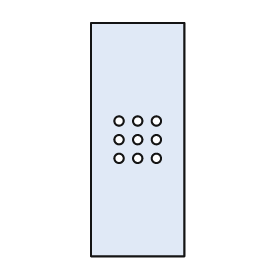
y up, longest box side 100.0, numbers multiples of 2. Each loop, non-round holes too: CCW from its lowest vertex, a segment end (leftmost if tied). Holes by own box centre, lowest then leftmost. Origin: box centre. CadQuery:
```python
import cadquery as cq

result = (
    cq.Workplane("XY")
    .moveTo(-20.0, -50.0)
    .lineTo(20.0, -50.0)
    .lineTo(20.0, 50.0)
    .lineTo(-20.0, 50.0)
    .close()
    .moveTo(-8.0, -8.0)
    .circle(2.0)
    .moveTo(0.0, -8.0)
    .circle(2.0)
    .moveTo(8.0, -8.0)
    .circle(2.0)
    .moveTo(-8.0, 0.0)
    .circle(2.0)
    .moveTo(0.0, 0.0)
    .circle(2.0)
    .moveTo(8.0, 0.0)
    .circle(2.0)
    .moveTo(-8.0, 8.0)
    .circle(2.0)
    .moveTo(0.0, 8.0)
    .circle(2.0)
    .moveTo(8.0, 8.0)
    .circle(2.0)
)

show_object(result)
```